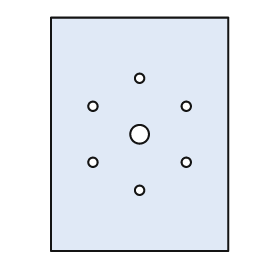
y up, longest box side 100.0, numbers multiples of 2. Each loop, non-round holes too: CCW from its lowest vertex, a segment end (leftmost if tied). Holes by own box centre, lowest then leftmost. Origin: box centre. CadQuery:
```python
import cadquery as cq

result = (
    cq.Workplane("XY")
    .moveTo(-38.0, -50.0)
    .lineTo(38.0, -50.0)
    .lineTo(38.0, 50.0)
    .lineTo(-38.0, 50.0)
    .close()
    .moveTo(0.0, -24.0)
    .circle(2.0)
    .moveTo(-20.0, -12.0)
    .circle(2.0)
    .moveTo(20.0, -12.0)
    .circle(2.0)
    .moveTo(0.0, 0.0)
    .circle(4.0)
    .moveTo(-20.0, 12.0)
    .circle(2.0)
    .moveTo(20.0, 12.0)
    .circle(2.0)
    .moveTo(0.0, 24.0)
    .circle(2.0)
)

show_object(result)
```